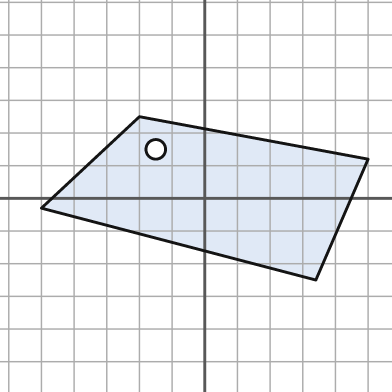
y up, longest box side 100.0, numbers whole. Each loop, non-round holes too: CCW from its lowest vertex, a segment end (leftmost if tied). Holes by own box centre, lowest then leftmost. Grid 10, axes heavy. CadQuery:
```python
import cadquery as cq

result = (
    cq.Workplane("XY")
    .moveTo(34.0, -25.0)
    .lineTo(50.0, 12.0)
    .lineTo(-20.0, 25.0)
    .lineTo(-50.0, -3.0)
    .close()
    .moveTo(-15.0, 15.0)
    .circle(3.0)
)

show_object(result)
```